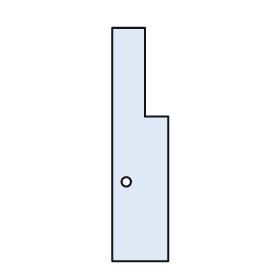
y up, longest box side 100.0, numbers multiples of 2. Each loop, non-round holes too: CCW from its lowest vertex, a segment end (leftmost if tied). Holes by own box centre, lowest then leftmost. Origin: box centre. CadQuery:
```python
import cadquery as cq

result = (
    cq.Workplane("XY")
    .moveTo(-12.0, -50.0)
    .lineTo(12.0, -50.0)
    .lineTo(12.0, 12.0)
    .lineTo(2.0, 12.0)
    .lineTo(2.0, 50.0)
    .lineTo(-12.0, 50.0)
    .close()
    .moveTo(-6.0, -16.0)
    .circle(2.0)
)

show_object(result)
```